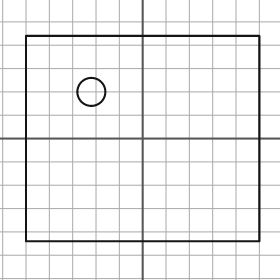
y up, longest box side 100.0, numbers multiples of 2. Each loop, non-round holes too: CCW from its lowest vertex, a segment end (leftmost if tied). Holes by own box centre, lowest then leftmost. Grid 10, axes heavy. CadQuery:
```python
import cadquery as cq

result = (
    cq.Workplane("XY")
    .moveTo(-50.0, -44.0)
    .lineTo(50.0, -44.0)
    .lineTo(50.0, 44.0)
    .lineTo(-50.0, 44.0)
    .close()
    .moveTo(-22.0, 20.0)
    .circle(6.0)
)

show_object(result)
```